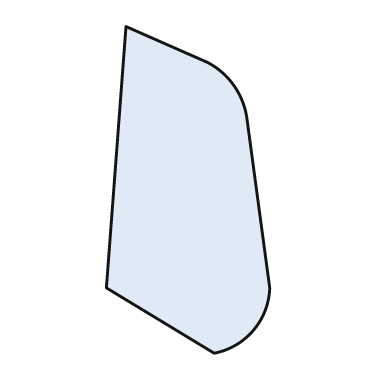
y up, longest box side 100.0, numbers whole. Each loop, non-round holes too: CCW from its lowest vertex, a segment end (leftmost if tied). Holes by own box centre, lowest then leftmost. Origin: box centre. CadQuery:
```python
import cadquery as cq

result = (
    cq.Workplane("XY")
    .moveTo(8.0, -50.0)
    .threePointArc((20.0, -43.0), (25.0, -30.0))
    .lineTo(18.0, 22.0)
    .threePointArc((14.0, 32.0), (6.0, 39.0))
    .lineTo(-19.0, 50.0)
    .lineTo(-25.0, -30.0)
    .close()
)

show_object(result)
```